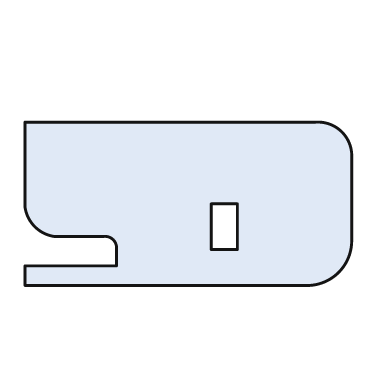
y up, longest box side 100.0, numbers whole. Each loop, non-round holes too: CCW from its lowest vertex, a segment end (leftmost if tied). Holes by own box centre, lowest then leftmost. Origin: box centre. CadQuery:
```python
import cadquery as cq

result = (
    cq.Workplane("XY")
    .moveTo(-50.0, -25.0)
    .lineTo(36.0, -25.0)
    .threePointArc((46.0, -21.0), (50.0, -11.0))
    .lineTo(50.0, 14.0)
    .threePointArc((47.0, 22.0), (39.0, 25.0))
    .lineTo(-50.0, 25.0)
    .lineTo(-50.0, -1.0)
    .threePointArc((-47.0, -7.0), (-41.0, -10.0))
    .lineTo(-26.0, -10.0)
    .threePointArc((-23.0, -11.0), (-22.0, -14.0))
    .lineTo(-22.0, -19.0)
    .lineTo(-50.0, -19.0)
    .close()
    .moveTo(7.0, -14.0)
    .lineTo(15.0, -14.0)
    .lineTo(15.0, 0.0)
    .lineTo(7.0, 0.0)
    .close()
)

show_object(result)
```